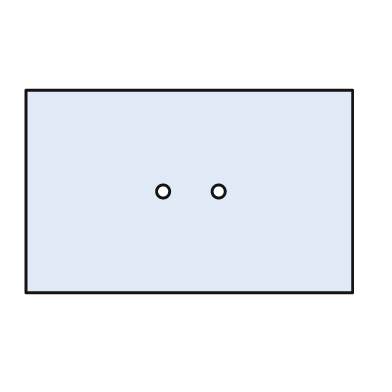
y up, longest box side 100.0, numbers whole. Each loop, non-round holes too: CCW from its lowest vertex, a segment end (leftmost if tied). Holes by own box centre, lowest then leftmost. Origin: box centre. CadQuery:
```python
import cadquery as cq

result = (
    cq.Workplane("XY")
    .moveTo(-50.0, -31.0)
    .lineTo(50.0, -31.0)
    .lineTo(50.0, 31.0)
    .lineTo(-50.0, 31.0)
    .close()
    .moveTo(-8.0, 0.0)
    .circle(2.0)
    .moveTo(9.0, 0.0)
    .circle(2.0)
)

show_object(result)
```